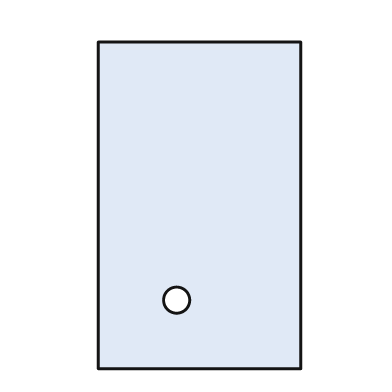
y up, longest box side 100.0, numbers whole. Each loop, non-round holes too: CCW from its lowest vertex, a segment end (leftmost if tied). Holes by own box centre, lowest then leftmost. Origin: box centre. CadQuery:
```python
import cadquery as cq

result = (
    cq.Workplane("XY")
    .moveTo(-31.0, -50.0)
    .lineTo(31.0, -50.0)
    .lineTo(31.0, 50.0)
    .lineTo(-31.0, 50.0)
    .close()
    .moveTo(-7.0, -29.0)
    .circle(4.0)
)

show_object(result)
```